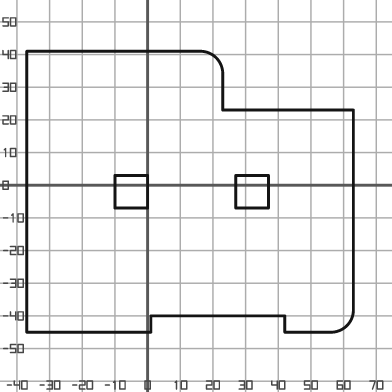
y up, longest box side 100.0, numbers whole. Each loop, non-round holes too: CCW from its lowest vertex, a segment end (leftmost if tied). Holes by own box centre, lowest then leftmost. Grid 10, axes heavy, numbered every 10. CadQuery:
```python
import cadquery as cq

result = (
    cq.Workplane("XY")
    .moveTo(-37.0, -45.0)
    .lineTo(1.0, -45.0)
    .lineTo(1.0, -40.0)
    .lineTo(42.0, -40.0)
    .lineTo(42.0, -45.0)
    .lineTo(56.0, -45.0)
    .threePointArc((61.0, -43.0), (63.0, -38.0))
    .lineTo(63.0, 23.0)
    .lineTo(23.0, 23.0)
    .lineTo(23.0, 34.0)
    .threePointArc((21.0, 39.0), (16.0, 41.0))
    .lineTo(-37.0, 41.0)
    .close()
    .moveTo(-10.0, -7.0)
    .lineTo(0.0, -7.0)
    .lineTo(0.0, 3.0)
    .lineTo(-10.0, 3.0)
    .close()
    .moveTo(27.0, -7.0)
    .lineTo(37.0, -7.0)
    .lineTo(37.0, 3.0)
    .lineTo(27.0, 3.0)
    .close()
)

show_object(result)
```